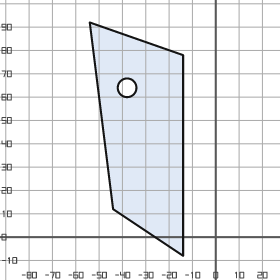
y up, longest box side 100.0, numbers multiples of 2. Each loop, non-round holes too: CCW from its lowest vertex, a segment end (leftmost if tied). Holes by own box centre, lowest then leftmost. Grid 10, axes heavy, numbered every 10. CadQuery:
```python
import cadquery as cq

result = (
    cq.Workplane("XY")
    .moveTo(-14.0, -8.0)
    .lineTo(-14.0, 78.0)
    .lineTo(-54.0, 92.0)
    .lineTo(-44.0, 12.0)
    .close()
    .moveTo(-38.0, 64.0)
    .circle(4.0)
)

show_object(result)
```